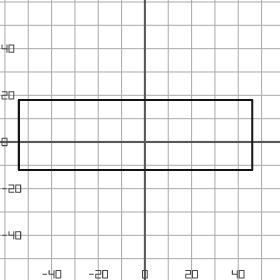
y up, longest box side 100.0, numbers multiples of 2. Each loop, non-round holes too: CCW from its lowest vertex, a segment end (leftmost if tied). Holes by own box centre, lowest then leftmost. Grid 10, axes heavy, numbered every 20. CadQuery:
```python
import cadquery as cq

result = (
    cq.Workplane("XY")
    .moveTo(-54.0, -12.0)
    .lineTo(46.0, -12.0)
    .lineTo(46.0, 18.0)
    .lineTo(-54.0, 18.0)
    .close()
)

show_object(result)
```